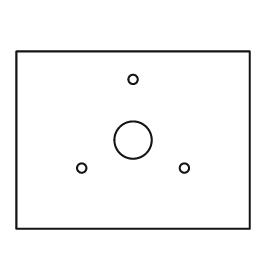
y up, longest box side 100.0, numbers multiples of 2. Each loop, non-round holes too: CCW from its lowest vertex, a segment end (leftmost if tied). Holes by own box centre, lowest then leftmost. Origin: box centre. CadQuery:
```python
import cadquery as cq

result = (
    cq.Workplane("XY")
    .moveTo(-50.0, -38.0)
    .lineTo(50.0, -38.0)
    .lineTo(50.0, 38.0)
    .lineTo(-50.0, 38.0)
    .close()
    .moveTo(-22.0, -12.0)
    .circle(2.0)
    .moveTo(22.0, -12.0)
    .circle(2.0)
    .moveTo(0.0, 0.0)
    .circle(8.0)
    .moveTo(0.0, 26.0)
    .circle(2.0)
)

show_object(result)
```